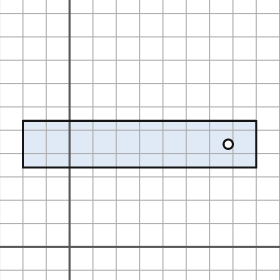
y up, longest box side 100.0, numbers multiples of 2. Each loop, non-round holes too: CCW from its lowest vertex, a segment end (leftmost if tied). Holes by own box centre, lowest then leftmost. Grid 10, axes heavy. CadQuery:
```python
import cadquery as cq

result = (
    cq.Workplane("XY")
    .moveTo(-20.0, 34.0)
    .lineTo(80.0, 34.0)
    .lineTo(80.0, 54.0)
    .lineTo(-20.0, 54.0)
    .close()
    .moveTo(68.0, 44.0)
    .circle(2.0)
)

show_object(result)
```